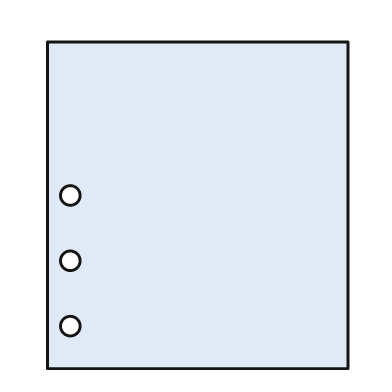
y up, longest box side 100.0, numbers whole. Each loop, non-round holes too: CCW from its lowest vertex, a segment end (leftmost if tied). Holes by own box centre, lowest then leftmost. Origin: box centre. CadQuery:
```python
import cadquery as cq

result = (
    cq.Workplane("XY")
    .moveTo(-46.0, -50.0)
    .lineTo(46.0, -50.0)
    .lineTo(46.0, 50.0)
    .lineTo(-46.0, 50.0)
    .close()
    .moveTo(-39.0, -37.0)
    .circle(3.0)
    .moveTo(-39.0, -17.0)
    .circle(3.0)
    .moveTo(-39.0, 3.0)
    .circle(3.0)
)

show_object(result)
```